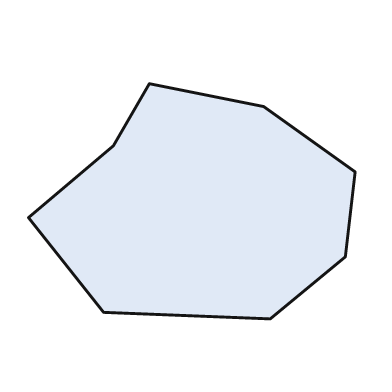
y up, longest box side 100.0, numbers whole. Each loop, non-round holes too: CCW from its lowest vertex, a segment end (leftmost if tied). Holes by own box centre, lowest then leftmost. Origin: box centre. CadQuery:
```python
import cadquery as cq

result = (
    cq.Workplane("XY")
    .moveTo(24.0, -36.0)
    .lineTo(47.0, -17.0)
    .lineTo(50.0, 9.0)
    .lineTo(22.0, 29.0)
    .lineTo(-13.0, 36.0)
    .lineTo(-24.0, 17.0)
    .lineTo(-50.0, -5.0)
    .lineTo(-27.0, -34.0)
    .close()
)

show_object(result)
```